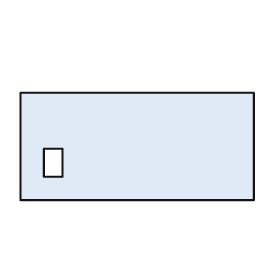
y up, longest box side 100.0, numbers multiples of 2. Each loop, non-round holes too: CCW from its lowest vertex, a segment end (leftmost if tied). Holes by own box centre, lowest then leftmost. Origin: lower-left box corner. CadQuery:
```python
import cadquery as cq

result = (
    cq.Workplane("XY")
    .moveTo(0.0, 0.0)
    .lineTo(100.0, 0.0)
    .lineTo(100.0, 46.0)
    .lineTo(0.0, 46.0)
    .close()
    .moveTo(10.0, 10.0)
    .lineTo(18.0, 10.0)
    .lineTo(18.0, 22.0)
    .lineTo(10.0, 22.0)
    .close()
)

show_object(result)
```